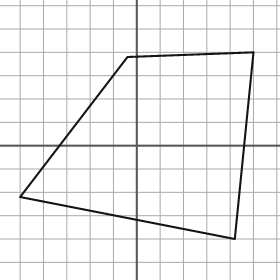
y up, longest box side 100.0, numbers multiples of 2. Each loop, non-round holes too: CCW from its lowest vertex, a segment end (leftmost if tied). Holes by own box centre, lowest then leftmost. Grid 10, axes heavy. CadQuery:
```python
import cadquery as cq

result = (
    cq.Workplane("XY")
    .moveTo(42.0, -40.0)
    .lineTo(50.0, 40.0)
    .lineTo(-4.0, 38.0)
    .lineTo(-50.0, -22.0)
    .close()
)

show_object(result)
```